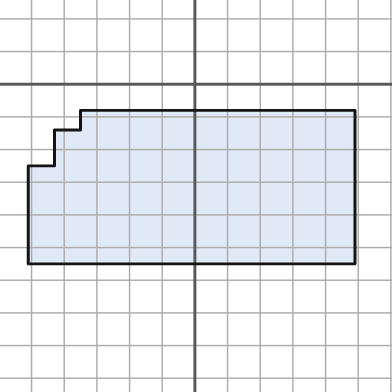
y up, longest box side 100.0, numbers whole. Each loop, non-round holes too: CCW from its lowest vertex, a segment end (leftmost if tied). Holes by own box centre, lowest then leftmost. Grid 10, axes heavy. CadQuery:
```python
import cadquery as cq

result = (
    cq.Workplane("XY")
    .moveTo(-51.0, -55.0)
    .lineTo(49.0, -55.0)
    .lineTo(49.0, -8.0)
    .lineTo(-35.0, -8.0)
    .lineTo(-35.0, -14.0)
    .lineTo(-43.0, -14.0)
    .lineTo(-43.0, -25.0)
    .lineTo(-51.0, -25.0)
    .close()
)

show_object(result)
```